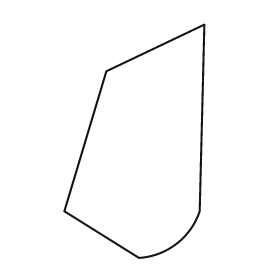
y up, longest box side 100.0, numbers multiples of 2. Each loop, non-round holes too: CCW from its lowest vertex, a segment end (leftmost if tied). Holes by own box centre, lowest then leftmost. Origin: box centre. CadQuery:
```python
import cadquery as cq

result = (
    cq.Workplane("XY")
    .moveTo(2.0, -50.0)
    .threePointArc((18.0, -44.0), (28.0, -30.0))
    .lineTo(30.0, 50.0)
    .lineTo(-12.0, 30.0)
    .lineTo(-30.0, -30.0)
    .close()
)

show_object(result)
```